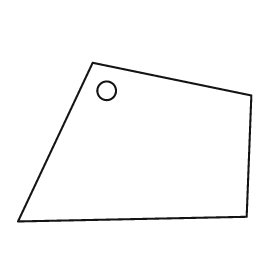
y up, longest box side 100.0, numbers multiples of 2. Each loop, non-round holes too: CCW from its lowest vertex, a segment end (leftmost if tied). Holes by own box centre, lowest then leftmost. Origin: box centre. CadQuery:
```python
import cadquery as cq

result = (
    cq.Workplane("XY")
    .moveTo(-50.0, -34.0)
    .lineTo(48.0, -32.0)
    .lineTo(50.0, 20.0)
    .lineTo(-18.0, 34.0)
    .close()
    .moveTo(-12.0, 22.0)
    .circle(4.0)
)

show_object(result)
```